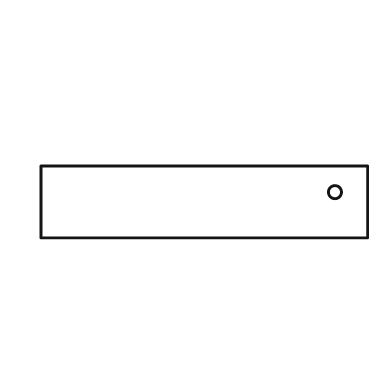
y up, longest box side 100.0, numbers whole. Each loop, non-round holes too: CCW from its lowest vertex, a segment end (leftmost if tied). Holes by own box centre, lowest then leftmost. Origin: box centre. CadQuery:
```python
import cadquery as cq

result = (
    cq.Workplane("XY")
    .moveTo(-50.0, -11.0)
    .lineTo(50.0, -11.0)
    .lineTo(50.0, 11.0)
    .lineTo(-50.0, 11.0)
    .close()
    .moveTo(40.0, 3.0)
    .circle(2.0)
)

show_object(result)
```